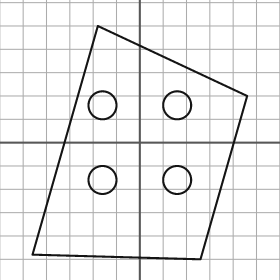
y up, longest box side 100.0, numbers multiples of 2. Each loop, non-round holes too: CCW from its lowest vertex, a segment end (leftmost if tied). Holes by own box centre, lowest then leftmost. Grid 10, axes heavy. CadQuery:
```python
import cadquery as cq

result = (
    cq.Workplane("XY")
    .moveTo(26.0, -50.0)
    .lineTo(46.0, 20.0)
    .lineTo(-18.0, 50.0)
    .lineTo(-46.0, -48.0)
    .close()
    .moveTo(-16.0, -16.0)
    .circle(6.0)
    .moveTo(16.0, -16.0)
    .circle(6.0)
    .moveTo(-16.0, 16.0)
    .circle(6.0)
    .moveTo(16.0, 16.0)
    .circle(6.0)
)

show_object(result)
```